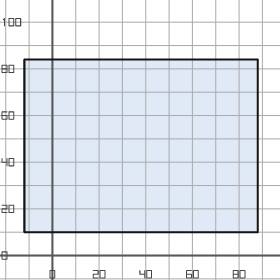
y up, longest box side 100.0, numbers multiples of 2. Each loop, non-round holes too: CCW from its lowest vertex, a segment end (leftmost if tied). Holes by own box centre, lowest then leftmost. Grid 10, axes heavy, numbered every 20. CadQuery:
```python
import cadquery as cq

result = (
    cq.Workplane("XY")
    .moveTo(-12.0, 10.0)
    .lineTo(88.0, 10.0)
    .lineTo(88.0, 84.0)
    .lineTo(-12.0, 84.0)
    .close()
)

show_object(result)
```